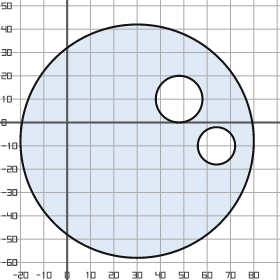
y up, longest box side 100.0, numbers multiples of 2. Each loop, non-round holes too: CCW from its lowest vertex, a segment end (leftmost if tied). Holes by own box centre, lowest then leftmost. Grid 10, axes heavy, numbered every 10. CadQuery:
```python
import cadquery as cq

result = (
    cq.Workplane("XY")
    .moveTo(30.0, -8.0)
    .circle(50.0)
    .moveTo(64.0, -10.0)
    .circle(8.0)
    .moveTo(48.0, 10.0)
    .circle(10.0)
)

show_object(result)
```